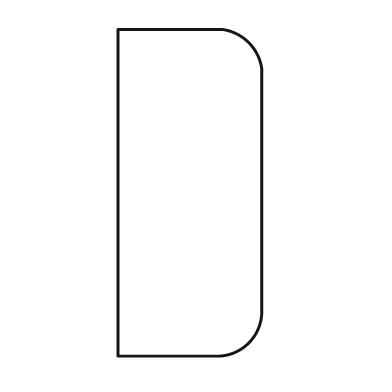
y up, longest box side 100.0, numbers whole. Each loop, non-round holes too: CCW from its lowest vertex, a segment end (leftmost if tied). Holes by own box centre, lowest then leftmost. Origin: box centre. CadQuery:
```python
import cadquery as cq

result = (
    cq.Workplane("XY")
    .moveTo(-22.0, -50.0)
    .lineTo(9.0, -50.0)
    .threePointArc((18.0, -46.0), (22.0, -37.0))
    .lineTo(22.0, 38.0)
    .threePointArc((18.0, 46.0), (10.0, 50.0))
    .lineTo(-22.0, 50.0)
    .close()
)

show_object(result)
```